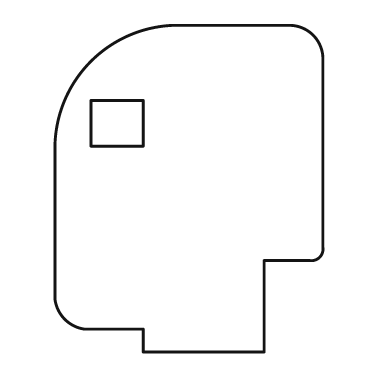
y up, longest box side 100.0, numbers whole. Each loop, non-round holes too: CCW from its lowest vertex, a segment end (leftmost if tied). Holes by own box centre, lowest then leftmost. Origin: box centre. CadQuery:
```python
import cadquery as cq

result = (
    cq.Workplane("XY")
    .moveTo(-14.0, -50.0)
    .lineTo(23.0, -50.0)
    .lineTo(23.0, -22.0)
    .lineTo(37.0, -22.0)
    .threePointArc((40.0, -21.0), (41.0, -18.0))
    .lineTo(41.0, 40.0)
    .threePointArc((38.0, 47.0), (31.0, 50.0))
    .lineTo(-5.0, 50.0)
    .threePointArc((-30.0, 39.0), (-41.0, 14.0))
    .lineTo(-41.0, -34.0)
    .threePointArc((-38.0, -40.0), (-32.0, -43.0))
    .lineTo(-14.0, -43.0)
    .close()
    .moveTo(-30.0, 13.0)
    .lineTo(-14.0, 13.0)
    .lineTo(-14.0, 27.0)
    .lineTo(-30.0, 27.0)
    .close()
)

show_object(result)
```